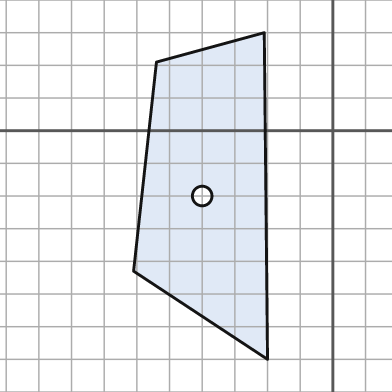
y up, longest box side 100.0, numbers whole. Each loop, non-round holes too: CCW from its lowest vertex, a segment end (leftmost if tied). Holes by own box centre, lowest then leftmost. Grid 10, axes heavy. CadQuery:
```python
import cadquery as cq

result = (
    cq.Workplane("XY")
    .moveTo(-20.0, -70.0)
    .lineTo(-21.0, 30.0)
    .lineTo(-54.0, 21.0)
    .lineTo(-61.0, -43.0)
    .close()
    .moveTo(-40.0, -20.0)
    .circle(3.0)
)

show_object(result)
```